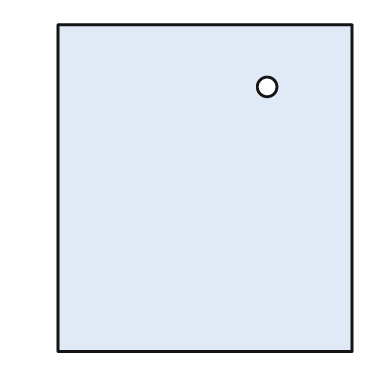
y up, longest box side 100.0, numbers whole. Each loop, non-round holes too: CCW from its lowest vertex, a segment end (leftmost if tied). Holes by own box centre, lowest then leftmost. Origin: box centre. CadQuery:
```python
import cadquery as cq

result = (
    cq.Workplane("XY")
    .moveTo(-45.0, -50.0)
    .lineTo(45.0, -50.0)
    .lineTo(45.0, 50.0)
    .lineTo(-45.0, 50.0)
    .close()
    .moveTo(19.0, 31.0)
    .circle(3.0)
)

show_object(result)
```